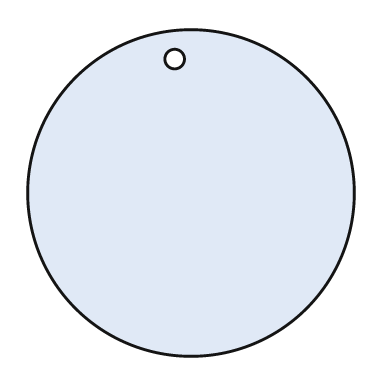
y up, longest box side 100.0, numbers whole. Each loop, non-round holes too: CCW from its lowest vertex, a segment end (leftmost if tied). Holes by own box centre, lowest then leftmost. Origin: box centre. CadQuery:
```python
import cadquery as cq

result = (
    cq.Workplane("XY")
    .moveTo(0.0, 0.0)
    .circle(50.0)
    .moveTo(-5.0, 41.0)
    .circle(3.0)
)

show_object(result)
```